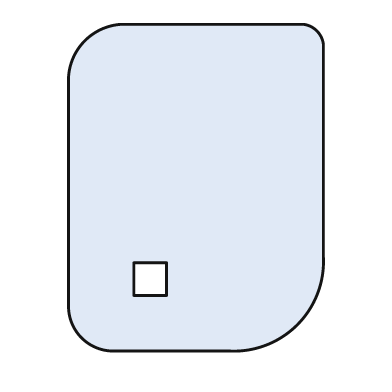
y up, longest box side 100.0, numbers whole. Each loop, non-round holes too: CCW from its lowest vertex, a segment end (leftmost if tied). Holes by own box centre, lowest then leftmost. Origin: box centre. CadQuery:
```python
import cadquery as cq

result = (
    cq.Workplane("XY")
    .moveTo(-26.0, -50.0)
    .lineTo(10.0, -50.0)
    .threePointArc((31.0, -42.0), (39.0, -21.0))
    .lineTo(39.0, 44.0)
    .threePointArc((37.0, 48.0), (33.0, 50.0))
    .lineTo(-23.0, 50.0)
    .threePointArc((-34.0, 45.0), (-39.0, 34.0))
    .lineTo(-39.0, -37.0)
    .threePointArc((-35.0, -46.0), (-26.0, -50.0))
    .close()
    .moveTo(-19.0, -33.0)
    .lineTo(-9.0, -33.0)
    .lineTo(-9.0, -23.0)
    .lineTo(-19.0, -23.0)
    .close()
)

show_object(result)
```